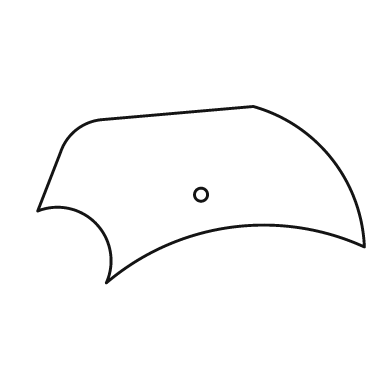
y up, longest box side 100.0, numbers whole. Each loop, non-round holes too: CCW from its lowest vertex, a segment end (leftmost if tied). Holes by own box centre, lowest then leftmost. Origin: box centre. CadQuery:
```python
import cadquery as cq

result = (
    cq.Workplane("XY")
    .moveTo(-29.0, -27.0)
    .threePointArc((9.0, -10.0), (50.0, -16.0))
    .threePointArc((40.0, 11.0), (16.0, 27.0))
    .lineTo(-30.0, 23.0)
    .threePointArc((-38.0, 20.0), (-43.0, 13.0))
    .lineTo(-50.0, -5.0)
    .threePointArc((-32.0, -9.0), (-29.0, -27.0))
    .close()
    .moveTo(0.0, 0.0)
    .circle(2.0)
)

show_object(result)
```